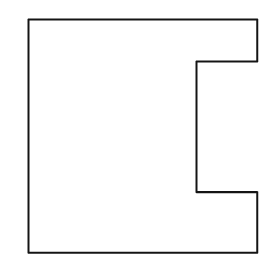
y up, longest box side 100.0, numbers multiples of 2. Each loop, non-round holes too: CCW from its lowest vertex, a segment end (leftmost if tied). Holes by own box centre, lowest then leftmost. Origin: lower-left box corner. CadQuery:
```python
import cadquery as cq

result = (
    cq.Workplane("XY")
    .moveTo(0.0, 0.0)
    .lineTo(98.0, 0.0)
    .lineTo(98.0, 26.0)
    .lineTo(72.0, 26.0)
    .lineTo(72.0, 82.0)
    .lineTo(98.0, 82.0)
    .lineTo(98.0, 100.0)
    .lineTo(0.0, 100.0)
    .close()
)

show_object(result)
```